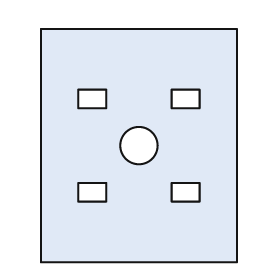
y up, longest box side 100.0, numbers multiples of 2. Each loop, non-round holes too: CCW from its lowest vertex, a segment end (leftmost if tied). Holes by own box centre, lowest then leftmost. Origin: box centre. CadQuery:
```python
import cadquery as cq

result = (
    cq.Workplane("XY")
    .moveTo(-42.0, -50.0)
    .lineTo(42.0, -50.0)
    .lineTo(42.0, 50.0)
    .lineTo(-42.0, 50.0)
    .close()
    .moveTo(-26.0, -24.0)
    .lineTo(-14.0, -24.0)
    .lineTo(-14.0, -16.0)
    .lineTo(-26.0, -16.0)
    .close()
    .moveTo(14.0, -24.0)
    .lineTo(26.0, -24.0)
    .lineTo(26.0, -16.0)
    .lineTo(14.0, -16.0)
    .close()
    .moveTo(0.0, 0.0)
    .circle(8.0)
    .moveTo(-26.0, 16.0)
    .lineTo(-14.0, 16.0)
    .lineTo(-14.0, 24.0)
    .lineTo(-26.0, 24.0)
    .close()
    .moveTo(14.0, 16.0)
    .lineTo(26.0, 16.0)
    .lineTo(26.0, 24.0)
    .lineTo(14.0, 24.0)
    .close()
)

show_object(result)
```